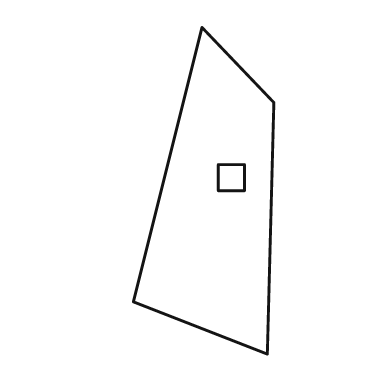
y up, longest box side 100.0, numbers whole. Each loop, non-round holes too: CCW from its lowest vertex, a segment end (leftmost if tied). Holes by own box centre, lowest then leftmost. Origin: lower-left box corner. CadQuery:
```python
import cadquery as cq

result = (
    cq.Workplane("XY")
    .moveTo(41.0, 0.0)
    .lineTo(43.0, 77.0)
    .lineTo(21.0, 100.0)
    .lineTo(0.0, 16.0)
    .close()
    .moveTo(26.0, 50.0)
    .lineTo(34.0, 50.0)
    .lineTo(34.0, 58.0)
    .lineTo(26.0, 58.0)
    .close()
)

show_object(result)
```